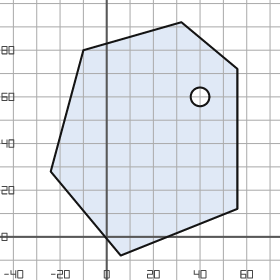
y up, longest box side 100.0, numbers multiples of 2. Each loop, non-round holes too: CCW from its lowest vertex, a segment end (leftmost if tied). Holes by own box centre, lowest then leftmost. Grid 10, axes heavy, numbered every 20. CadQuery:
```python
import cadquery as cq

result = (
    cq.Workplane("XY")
    .moveTo(6.0, -8.0)
    .lineTo(56.0, 12.0)
    .lineTo(56.0, 72.0)
    .lineTo(32.0, 92.0)
    .lineTo(-10.0, 80.0)
    .lineTo(-24.0, 28.0)
    .close()
    .moveTo(40.0, 60.0)
    .circle(4.0)
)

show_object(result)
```